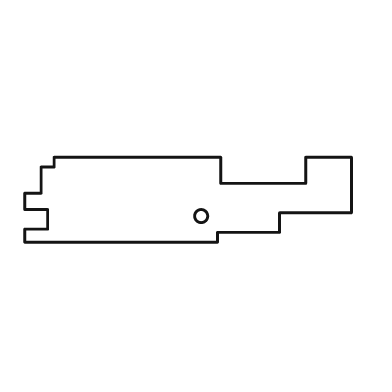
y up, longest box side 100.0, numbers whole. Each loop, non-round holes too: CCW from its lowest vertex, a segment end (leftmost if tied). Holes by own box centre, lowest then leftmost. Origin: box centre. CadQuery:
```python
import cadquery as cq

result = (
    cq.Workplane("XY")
    .moveTo(-50.0, -13.0)
    .lineTo(9.0, -13.0)
    .lineTo(9.0, -10.0)
    .lineTo(28.0, -10.0)
    .lineTo(28.0, -4.0)
    .lineTo(50.0, -4.0)
    .lineTo(50.0, 13.0)
    .lineTo(36.0, 13.0)
    .lineTo(36.0, 5.0)
    .lineTo(10.0, 5.0)
    .lineTo(10.0, 13.0)
    .lineTo(-41.0, 13.0)
    .lineTo(-41.0, 10.0)
    .lineTo(-45.0, 10.0)
    .lineTo(-45.0, 2.0)
    .lineTo(-50.0, 2.0)
    .lineTo(-50.0, -3.0)
    .lineTo(-43.0, -3.0)
    .lineTo(-43.0, -9.0)
    .lineTo(-50.0, -9.0)
    .close()
    .moveTo(4.0, -5.0)
    .circle(2.0)
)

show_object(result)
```